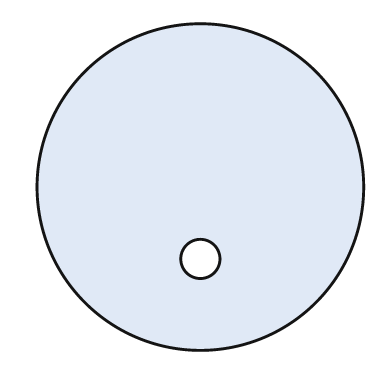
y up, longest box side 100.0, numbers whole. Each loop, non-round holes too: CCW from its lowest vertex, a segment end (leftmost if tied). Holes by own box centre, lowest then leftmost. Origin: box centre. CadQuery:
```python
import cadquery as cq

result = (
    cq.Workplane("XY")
    .moveTo(0.0, 0.0)
    .circle(50.0)
    .moveTo(0.0, -22.0)
    .circle(6.0)
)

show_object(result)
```